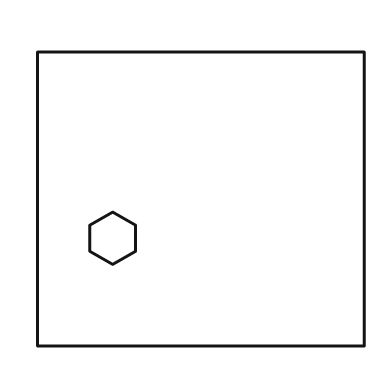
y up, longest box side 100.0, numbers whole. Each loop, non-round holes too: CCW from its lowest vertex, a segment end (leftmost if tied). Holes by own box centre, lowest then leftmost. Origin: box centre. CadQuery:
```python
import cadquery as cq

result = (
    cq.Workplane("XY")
    .moveTo(-50.0, -45.0)
    .lineTo(50.0, -45.0)
    .lineTo(50.0, 45.0)
    .lineTo(-50.0, 45.0)
    .close()
    .moveTo(-27.0, -20.0)
    .lineTo(-20.0, -16.0)
    .lineTo(-20.0, -8.0)
    .lineTo(-27.0, -4.0)
    .lineTo(-34.0, -8.0)
    .lineTo(-34.0, -16.0)
    .close()
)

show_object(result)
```